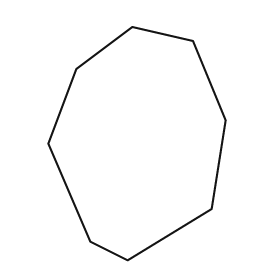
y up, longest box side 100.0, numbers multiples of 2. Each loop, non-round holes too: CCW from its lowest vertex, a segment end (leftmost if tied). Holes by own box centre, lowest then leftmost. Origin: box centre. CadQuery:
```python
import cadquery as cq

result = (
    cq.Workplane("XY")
    .moveTo(-4.0, -50.0)
    .lineTo(32.0, -28.0)
    .lineTo(38.0, 10.0)
    .lineTo(24.0, 44.0)
    .lineTo(-2.0, 50.0)
    .lineTo(-26.0, 32.0)
    .lineTo(-38.0, 0.0)
    .lineTo(-20.0, -42.0)
    .close()
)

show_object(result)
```